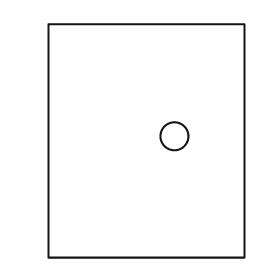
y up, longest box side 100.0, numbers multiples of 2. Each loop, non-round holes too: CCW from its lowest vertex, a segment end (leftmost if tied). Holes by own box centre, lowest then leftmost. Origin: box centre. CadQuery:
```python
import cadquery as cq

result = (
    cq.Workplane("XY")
    .moveTo(-42.0, -50.0)
    .lineTo(42.0, -50.0)
    .lineTo(42.0, 50.0)
    .lineTo(-42.0, 50.0)
    .close()
    .moveTo(12.0, 2.0)
    .circle(6.0)
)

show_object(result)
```